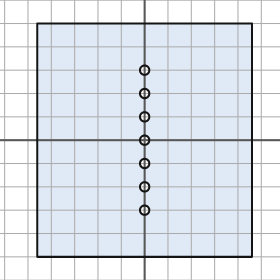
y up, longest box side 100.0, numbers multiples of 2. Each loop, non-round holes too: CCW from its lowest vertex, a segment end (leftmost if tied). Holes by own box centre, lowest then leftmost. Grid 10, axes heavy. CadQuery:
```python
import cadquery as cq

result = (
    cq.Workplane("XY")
    .moveTo(-46.0, -50.0)
    .lineTo(46.0, -50.0)
    .lineTo(46.0, 50.0)
    .lineTo(-46.0, 50.0)
    .close()
    .moveTo(0.0, -30.0)
    .circle(2.0)
    .moveTo(0.0, -20.0)
    .circle(2.0)
    .moveTo(0.0, -10.0)
    .circle(2.0)
    .moveTo(0.0, 0.0)
    .circle(2.0)
    .moveTo(0.0, 10.0)
    .circle(2.0)
    .moveTo(0.0, 20.0)
    .circle(2.0)
    .moveTo(0.0, 30.0)
    .circle(2.0)
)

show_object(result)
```